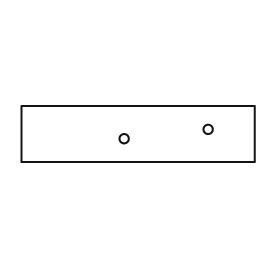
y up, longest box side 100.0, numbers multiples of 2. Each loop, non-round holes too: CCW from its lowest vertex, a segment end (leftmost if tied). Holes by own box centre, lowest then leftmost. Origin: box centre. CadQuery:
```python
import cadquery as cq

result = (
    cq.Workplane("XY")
    .moveTo(-50.0, -12.0)
    .lineTo(50.0, -12.0)
    .lineTo(50.0, 12.0)
    .lineTo(-50.0, 12.0)
    .close()
    .moveTo(-6.0, -2.0)
    .circle(2.0)
    .moveTo(30.0, 2.0)
    .circle(2.0)
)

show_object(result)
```